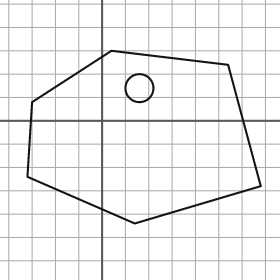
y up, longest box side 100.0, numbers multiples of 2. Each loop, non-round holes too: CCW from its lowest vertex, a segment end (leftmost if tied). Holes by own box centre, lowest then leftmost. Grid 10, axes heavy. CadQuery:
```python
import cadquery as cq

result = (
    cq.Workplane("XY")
    .moveTo(14.0, -44.0)
    .lineTo(68.0, -28.0)
    .lineTo(54.0, 24.0)
    .lineTo(4.0, 30.0)
    .lineTo(-30.0, 8.0)
    .lineTo(-32.0, -24.0)
    .close()
    .moveTo(16.0, 14.0)
    .circle(6.0)
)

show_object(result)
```